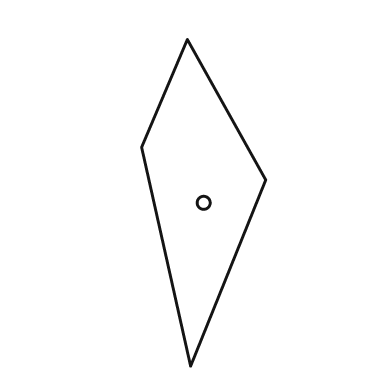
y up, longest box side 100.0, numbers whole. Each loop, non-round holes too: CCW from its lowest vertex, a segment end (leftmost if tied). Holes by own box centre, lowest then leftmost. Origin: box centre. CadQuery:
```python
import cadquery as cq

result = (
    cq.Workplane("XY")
    .moveTo(-4.0, -50.0)
    .lineTo(19.0, 7.0)
    .lineTo(-5.0, 50.0)
    .lineTo(-19.0, 17.0)
    .close()
    .moveTo(0.0, 0.0)
    .circle(2.0)
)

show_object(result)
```